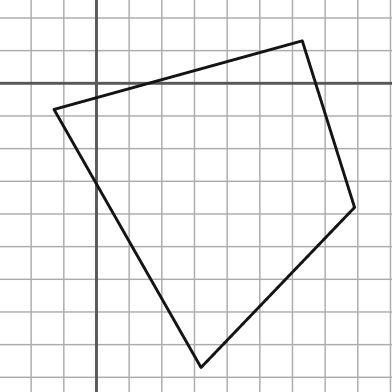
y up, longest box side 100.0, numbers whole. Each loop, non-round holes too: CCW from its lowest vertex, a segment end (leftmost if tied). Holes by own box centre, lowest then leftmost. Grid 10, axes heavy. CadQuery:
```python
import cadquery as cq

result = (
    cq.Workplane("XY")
    .moveTo(32.0, -87.0)
    .lineTo(79.0, -38.0)
    .lineTo(63.0, 13.0)
    .lineTo(-13.0, -8.0)
    .close()
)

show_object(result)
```